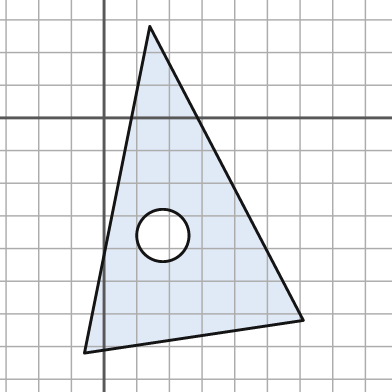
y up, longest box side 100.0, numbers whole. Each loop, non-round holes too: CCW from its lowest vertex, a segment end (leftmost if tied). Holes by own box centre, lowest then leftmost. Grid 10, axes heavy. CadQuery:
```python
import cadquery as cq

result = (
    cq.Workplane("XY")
    .moveTo(-6.0, -72.0)
    .lineTo(61.0, -62.0)
    .lineTo(14.0, 28.0)
    .close()
    .moveTo(18.0, -36.0)
    .circle(8.0)
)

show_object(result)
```